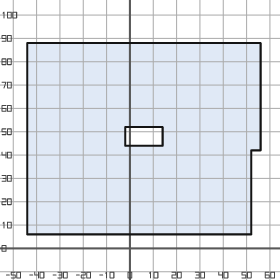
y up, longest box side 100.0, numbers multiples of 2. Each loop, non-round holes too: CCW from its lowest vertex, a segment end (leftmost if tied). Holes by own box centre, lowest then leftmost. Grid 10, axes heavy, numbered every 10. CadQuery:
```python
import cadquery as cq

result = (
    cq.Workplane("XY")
    .moveTo(-44.0, 6.0)
    .lineTo(52.0, 6.0)
    .lineTo(52.0, 42.0)
    .lineTo(56.0, 42.0)
    .lineTo(56.0, 88.0)
    .lineTo(-44.0, 88.0)
    .close()
    .moveTo(-2.0, 44.0)
    .lineTo(14.0, 44.0)
    .lineTo(14.0, 52.0)
    .lineTo(-2.0, 52.0)
    .close()
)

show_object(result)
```